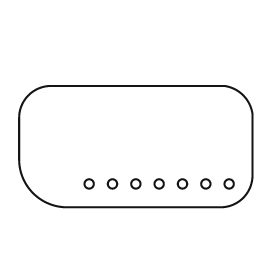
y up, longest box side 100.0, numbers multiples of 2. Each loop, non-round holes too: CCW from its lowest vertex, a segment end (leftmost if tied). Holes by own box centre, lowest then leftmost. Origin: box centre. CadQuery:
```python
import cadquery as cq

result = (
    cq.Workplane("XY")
    .moveTo(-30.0, -26.0)
    .lineTo(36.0, -26.0)
    .threePointArc((46.0, -22.0), (50.0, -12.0))
    .lineTo(50.0, 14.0)
    .threePointArc((46.0, 22.0), (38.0, 26.0))
    .lineTo(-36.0, 26.0)
    .threePointArc((-46.0, 22.0), (-50.0, 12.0))
    .lineTo(-50.0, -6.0)
    .threePointArc((-44.0, -20.0), (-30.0, -26.0))
    .close()
    .moveTo(-20.0, -16.0)
    .circle(2.0)
    .moveTo(-10.0, -16.0)
    .circle(2.0)
    .moveTo(0.0, -16.0)
    .circle(2.0)
    .moveTo(10.0, -16.0)
    .circle(2.0)
    .moveTo(20.0, -16.0)
    .circle(2.0)
    .moveTo(30.0, -16.0)
    .circle(2.0)
    .moveTo(40.0, -16.0)
    .circle(2.0)
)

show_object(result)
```